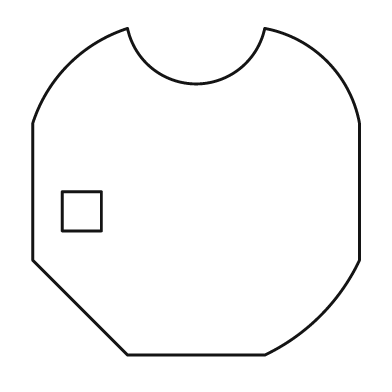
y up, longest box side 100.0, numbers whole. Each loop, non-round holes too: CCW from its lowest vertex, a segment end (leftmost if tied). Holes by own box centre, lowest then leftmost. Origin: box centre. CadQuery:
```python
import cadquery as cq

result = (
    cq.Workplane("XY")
    .moveTo(-21.0, -50.0)
    .lineTo(21.0, -50.0)
    .threePointArc((38.0, -38.0), (50.0, -21.0))
    .lineTo(50.0, 21.0)
    .threePointArc((40.0, 40.0), (21.0, 50.0))
    .threePointArc((0.0, 33.0), (-21.0, 50.0))
    .threePointArc((-39.0, 39.0), (-50.0, 21.0))
    .lineTo(-50.0, -21.0)
    .close()
    .moveTo(-41.0, -12.0)
    .lineTo(-29.0, -12.0)
    .lineTo(-29.0, 0.0)
    .lineTo(-41.0, 0.0)
    .close()
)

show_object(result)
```